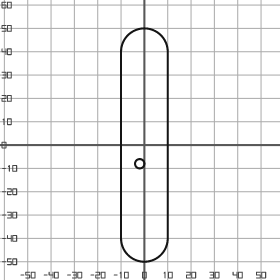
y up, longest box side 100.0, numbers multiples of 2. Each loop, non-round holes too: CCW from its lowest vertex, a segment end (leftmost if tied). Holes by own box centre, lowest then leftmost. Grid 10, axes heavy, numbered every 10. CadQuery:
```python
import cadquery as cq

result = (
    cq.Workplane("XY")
    .moveTo(-10.0, -40.0)
    .threePointArc((0.0, -50.0), (10.0, -40.0))
    .lineTo(10.0, 40.0)
    .threePointArc((0.0, 50.0), (-10.0, 40.0))
    .close()
    .moveTo(-2.0, -8.0)
    .circle(2.0)
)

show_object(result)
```